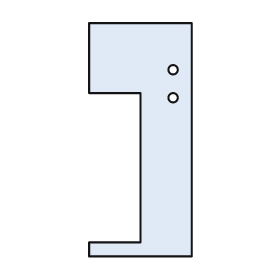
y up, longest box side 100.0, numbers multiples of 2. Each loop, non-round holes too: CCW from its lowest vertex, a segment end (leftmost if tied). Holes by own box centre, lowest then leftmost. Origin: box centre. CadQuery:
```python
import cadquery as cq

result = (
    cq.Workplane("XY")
    .moveTo(-22.0, -50.0)
    .lineTo(22.0, -50.0)
    .lineTo(22.0, 50.0)
    .lineTo(-22.0, 50.0)
    .lineTo(-22.0, 20.0)
    .lineTo(0.0, 20.0)
    .lineTo(0.0, -44.0)
    .lineTo(-22.0, -44.0)
    .close()
    .moveTo(14.0, 18.0)
    .circle(2.0)
    .moveTo(14.0, 30.0)
    .circle(2.0)
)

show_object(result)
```